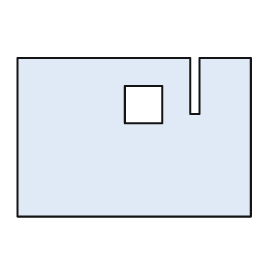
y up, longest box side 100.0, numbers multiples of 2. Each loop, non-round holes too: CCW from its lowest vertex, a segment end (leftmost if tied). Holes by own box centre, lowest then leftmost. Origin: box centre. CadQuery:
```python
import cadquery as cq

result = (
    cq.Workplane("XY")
    .moveTo(-50.0, -34.0)
    .lineTo(50.0, -34.0)
    .lineTo(50.0, 34.0)
    .lineTo(28.0, 34.0)
    .lineTo(28.0, 10.0)
    .lineTo(24.0, 10.0)
    .lineTo(24.0, 34.0)
    .lineTo(-50.0, 34.0)
    .close()
    .moveTo(-4.0, 6.0)
    .lineTo(12.0, 6.0)
    .lineTo(12.0, 22.0)
    .lineTo(-4.0, 22.0)
    .close()
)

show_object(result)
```